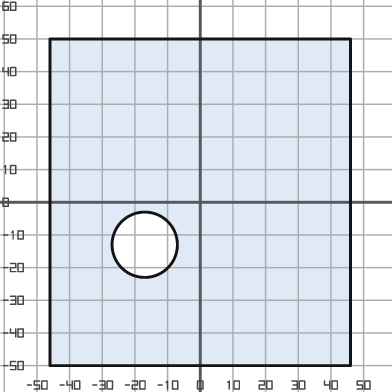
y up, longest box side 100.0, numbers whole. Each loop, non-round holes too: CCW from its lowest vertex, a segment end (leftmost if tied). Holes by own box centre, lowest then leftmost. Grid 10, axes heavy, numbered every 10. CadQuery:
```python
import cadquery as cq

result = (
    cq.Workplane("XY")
    .moveTo(-46.0, -50.0)
    .lineTo(46.0, -50.0)
    .lineTo(46.0, 50.0)
    .lineTo(-46.0, 50.0)
    .close()
    .moveTo(-17.0, -13.0)
    .circle(10.0)
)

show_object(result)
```